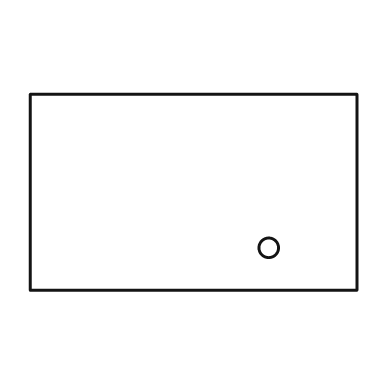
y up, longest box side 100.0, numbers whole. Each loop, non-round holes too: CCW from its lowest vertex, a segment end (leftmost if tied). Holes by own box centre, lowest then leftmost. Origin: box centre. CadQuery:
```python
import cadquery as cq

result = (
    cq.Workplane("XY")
    .moveTo(-50.0, -30.0)
    .lineTo(50.0, -30.0)
    .lineTo(50.0, 30.0)
    .lineTo(-50.0, 30.0)
    .close()
    .moveTo(23.0, -17.0)
    .circle(3.0)
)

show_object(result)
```